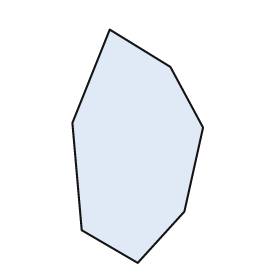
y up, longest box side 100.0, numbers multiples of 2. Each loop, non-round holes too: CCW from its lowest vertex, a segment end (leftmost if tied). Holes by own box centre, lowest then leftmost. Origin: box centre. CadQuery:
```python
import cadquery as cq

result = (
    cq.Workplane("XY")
    .moveTo(0.0, -50.0)
    .lineTo(20.0, -28.0)
    .lineTo(28.0, 8.0)
    .lineTo(14.0, 34.0)
    .lineTo(-12.0, 50.0)
    .lineTo(-28.0, 10.0)
    .lineTo(-24.0, -36.0)
    .close()
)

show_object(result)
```